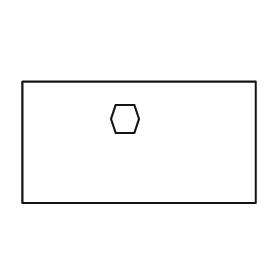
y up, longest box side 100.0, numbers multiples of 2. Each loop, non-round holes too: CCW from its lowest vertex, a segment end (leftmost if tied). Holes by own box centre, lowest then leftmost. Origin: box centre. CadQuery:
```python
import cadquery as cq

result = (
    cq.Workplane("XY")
    .moveTo(-50.0, -26.0)
    .lineTo(50.0, -26.0)
    .lineTo(50.0, 26.0)
    .lineTo(-50.0, 26.0)
    .close()
    .moveTo(-10.0, 4.0)
    .lineTo(-2.0, 4.0)
    .lineTo(0.0, 10.0)
    .lineTo(-2.0, 16.0)
    .lineTo(-10.0, 16.0)
    .lineTo(-12.0, 10.0)
    .close()
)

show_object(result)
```